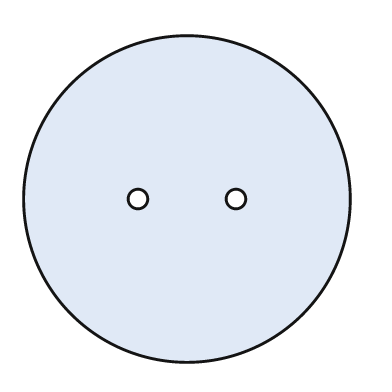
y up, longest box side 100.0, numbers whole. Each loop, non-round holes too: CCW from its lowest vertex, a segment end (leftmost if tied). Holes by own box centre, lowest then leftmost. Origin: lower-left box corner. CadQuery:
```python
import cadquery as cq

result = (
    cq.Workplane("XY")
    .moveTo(50.0, 50.0)
    .circle(50.0)
    .moveTo(35.0, 50.0)
    .circle(3.0)
    .moveTo(65.0, 50.0)
    .circle(3.0)
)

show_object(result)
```